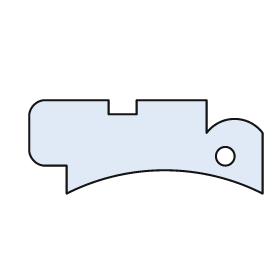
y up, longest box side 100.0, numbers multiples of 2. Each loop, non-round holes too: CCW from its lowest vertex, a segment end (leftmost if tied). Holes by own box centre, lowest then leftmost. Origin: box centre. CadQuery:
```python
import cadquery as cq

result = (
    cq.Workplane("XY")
    .moveTo(-34.0, -20.0)
    .threePointArc((8.0, -10.0), (50.0, -20.0))
    .lineTo(50.0, 6.0)
    .threePointArc((38.0, 12.0), (26.0, 6.0))
    .lineTo(26.0, 20.0)
    .lineTo(-4.0, 20.0)
    .lineTo(-4.0, 14.0)
    .lineTo(-16.0, 14.0)
    .lineTo(-16.0, 20.0)
    .lineTo(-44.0, 20.0)
    .threePointArc((-48.0, 18.0), (-50.0, 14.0))
    .lineTo(-50.0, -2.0)
    .threePointArc((-48.0, -6.0), (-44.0, -8.0))
    .lineTo(-34.0, -8.0)
    .close()
    .moveTo(34.0, -4.0)
    .circle(4.0)
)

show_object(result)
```